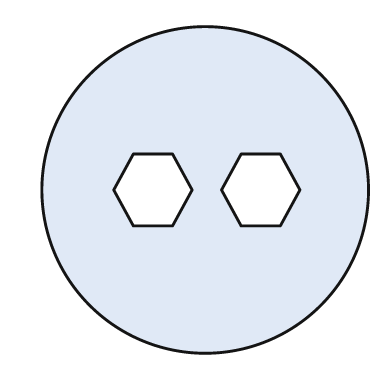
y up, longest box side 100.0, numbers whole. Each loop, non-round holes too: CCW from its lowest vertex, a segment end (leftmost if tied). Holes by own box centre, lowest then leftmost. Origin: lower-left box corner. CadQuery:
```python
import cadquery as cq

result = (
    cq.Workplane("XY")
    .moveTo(50.0, 50.0)
    .circle(50.0)
    .moveTo(28.0, 39.0)
    .lineTo(40.0, 39.0)
    .lineTo(46.0, 50.0)
    .lineTo(40.0, 61.0)
    .lineTo(28.0, 61.0)
    .lineTo(22.0, 50.0)
    .close()
    .moveTo(61.0, 39.0)
    .lineTo(73.0, 39.0)
    .lineTo(79.0, 50.0)
    .lineTo(73.0, 61.0)
    .lineTo(61.0, 61.0)
    .lineTo(55.0, 50.0)
    .close()
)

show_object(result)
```